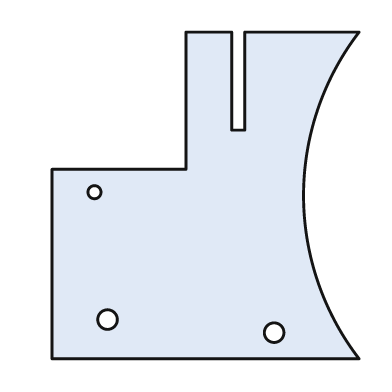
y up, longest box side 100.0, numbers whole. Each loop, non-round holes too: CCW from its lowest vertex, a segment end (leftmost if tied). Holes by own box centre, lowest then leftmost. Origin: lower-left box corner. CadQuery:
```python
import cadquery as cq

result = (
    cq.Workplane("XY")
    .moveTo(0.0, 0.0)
    .lineTo(94.0, 0.0)
    .threePointArc((77.0, 50.0), (94.0, 100.0))
    .lineTo(59.0, 100.0)
    .lineTo(59.0, 70.0)
    .lineTo(55.0, 70.0)
    .lineTo(55.0, 100.0)
    .lineTo(41.0, 100.0)
    .lineTo(41.0, 58.0)
    .lineTo(0.0, 58.0)
    .close()
    .moveTo(68.0, 8.0)
    .circle(3.0)
    .moveTo(17.0, 12.0)
    .circle(3.0)
    .moveTo(13.0, 51.0)
    .circle(2.0)
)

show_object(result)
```